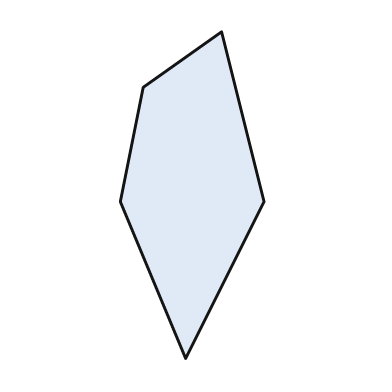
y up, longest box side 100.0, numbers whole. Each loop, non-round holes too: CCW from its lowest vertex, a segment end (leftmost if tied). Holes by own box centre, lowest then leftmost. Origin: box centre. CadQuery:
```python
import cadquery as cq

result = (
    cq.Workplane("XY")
    .moveTo(-2.0, -50.0)
    .lineTo(22.0, -2.0)
    .lineTo(9.0, 50.0)
    .lineTo(-15.0, 33.0)
    .lineTo(-22.0, -2.0)
    .close()
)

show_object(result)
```